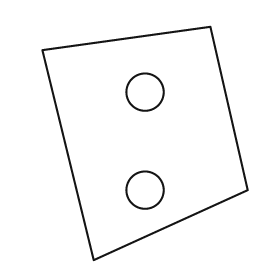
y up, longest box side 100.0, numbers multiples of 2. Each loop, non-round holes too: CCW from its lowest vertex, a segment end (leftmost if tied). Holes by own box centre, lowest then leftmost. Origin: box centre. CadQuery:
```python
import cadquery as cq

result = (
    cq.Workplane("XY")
    .moveTo(-22.0, -50.0)
    .lineTo(44.0, -20.0)
    .lineTo(28.0, 50.0)
    .lineTo(-44.0, 40.0)
    .close()
    .moveTo(0.0, -20.0)
    .circle(8.0)
    .moveTo(0.0, 22.0)
    .circle(8.0)
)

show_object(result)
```